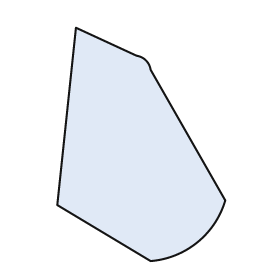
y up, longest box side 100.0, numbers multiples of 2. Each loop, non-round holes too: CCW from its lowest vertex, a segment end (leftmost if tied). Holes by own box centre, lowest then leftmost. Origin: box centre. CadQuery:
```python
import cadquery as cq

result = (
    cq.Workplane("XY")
    .moveTo(4.0, -50.0)
    .threePointArc((24.0, -42.0), (36.0, -24.0))
    .lineTo(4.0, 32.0)
    .threePointArc((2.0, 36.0), (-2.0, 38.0))
    .lineTo(-28.0, 50.0)
    .lineTo(-36.0, -26.0)
    .close()
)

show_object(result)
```